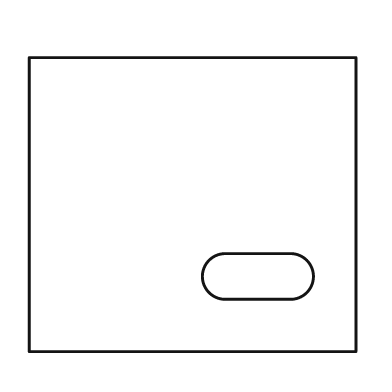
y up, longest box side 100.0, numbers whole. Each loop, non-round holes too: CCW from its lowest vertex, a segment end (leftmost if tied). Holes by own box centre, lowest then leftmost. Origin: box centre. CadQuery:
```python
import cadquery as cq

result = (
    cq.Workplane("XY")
    .moveTo(-50.0, -45.0)
    .lineTo(50.0, -45.0)
    .lineTo(50.0, 45.0)
    .lineTo(-50.0, 45.0)
    .close()
    .moveTo(10.0, -29.0)
    .lineTo(30.0, -29.0)
    .threePointArc((37.0, -22.0), (30.0, -15.0))
    .lineTo(10.0, -15.0)
    .threePointArc((3.0, -22.0), (10.0, -29.0))
    .close()
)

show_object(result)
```